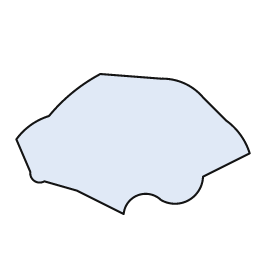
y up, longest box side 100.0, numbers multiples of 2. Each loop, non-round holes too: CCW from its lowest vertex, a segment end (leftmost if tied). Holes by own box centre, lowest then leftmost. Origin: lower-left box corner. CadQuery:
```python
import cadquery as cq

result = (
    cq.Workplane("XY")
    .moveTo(46.0, 0.0)
    .threePointArc((52.0, 8.0), (62.0, 6.0))
    .threePointArc((74.0, 6.0), (80.0, 16.0))
    .lineTo(100.0, 26.0)
    .threePointArc((96.0, 34.0), (90.0, 40.0))
    .lineTo(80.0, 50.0)
    .threePointArc((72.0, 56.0), (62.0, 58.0))
    .lineTo(36.0, 60.0)
    .threePointArc((24.0, 52.0), (14.0, 42.0))
    .threePointArc((6.0, 38.0), (0.0, 32.0))
    .lineTo(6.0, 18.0)
    .threePointArc((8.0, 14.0), (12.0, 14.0))
    .lineTo(26.0, 10.0)
    .close()
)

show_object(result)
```